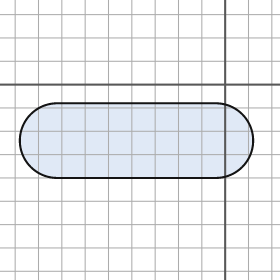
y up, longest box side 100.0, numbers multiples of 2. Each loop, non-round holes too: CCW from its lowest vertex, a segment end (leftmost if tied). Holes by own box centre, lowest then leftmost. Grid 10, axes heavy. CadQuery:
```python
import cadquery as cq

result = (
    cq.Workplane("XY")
    .moveTo(-72.0, -40.0)
    .lineTo(-4.0, -40.0)
    .threePointArc((12.0, -24.0), (-4.0, -8.0))
    .lineTo(-72.0, -8.0)
    .threePointArc((-88.0, -24.0), (-72.0, -40.0))
    .close()
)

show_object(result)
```